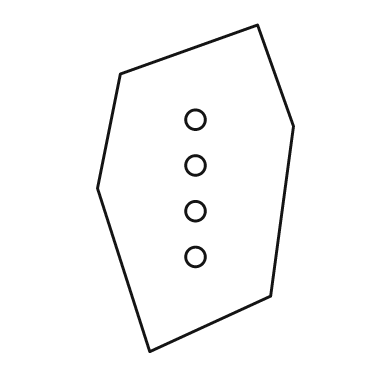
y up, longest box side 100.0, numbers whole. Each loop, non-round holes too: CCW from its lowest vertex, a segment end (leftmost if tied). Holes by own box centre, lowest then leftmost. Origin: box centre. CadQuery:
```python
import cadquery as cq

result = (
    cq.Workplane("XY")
    .moveTo(-14.0, -50.0)
    .lineTo(23.0, -33.0)
    .lineTo(30.0, 19.0)
    .lineTo(19.0, 50.0)
    .lineTo(-23.0, 35.0)
    .lineTo(-30.0, 0.0)
    .close()
    .moveTo(0.0, -21.0)
    .circle(3.0)
    .moveTo(0.0, -7.0)
    .circle(3.0)
    .moveTo(0.0, 7.0)
    .circle(3.0)
    .moveTo(0.0, 21.0)
    .circle(3.0)
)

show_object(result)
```